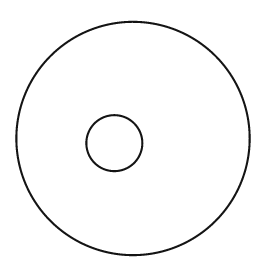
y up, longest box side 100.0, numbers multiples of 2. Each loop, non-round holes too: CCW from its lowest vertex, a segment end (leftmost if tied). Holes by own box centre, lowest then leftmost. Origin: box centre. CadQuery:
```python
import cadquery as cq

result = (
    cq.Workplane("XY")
    .moveTo(0.0, 0.0)
    .circle(50.0)
    .moveTo(-8.0, -2.0)
    .circle(12.0)
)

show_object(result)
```